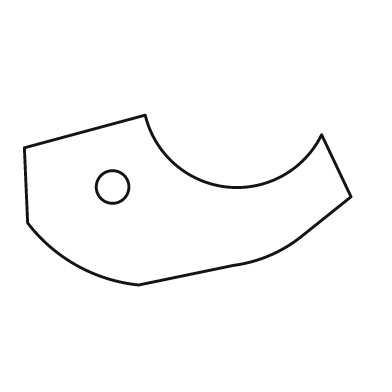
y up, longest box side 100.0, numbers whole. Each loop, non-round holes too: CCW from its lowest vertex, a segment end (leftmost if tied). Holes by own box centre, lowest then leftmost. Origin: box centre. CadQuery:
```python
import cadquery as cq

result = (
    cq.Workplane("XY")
    .moveTo(-15.0, -26.0)
    .lineTo(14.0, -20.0)
    .threePointArc((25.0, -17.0), (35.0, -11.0))
    .lineTo(50.0, 1.0)
    .lineTo(41.0, 20.0)
    .threePointArc((12.0, 4.0), (-13.0, 26.0))
    .lineTo(-50.0, 16.0)
    .lineTo(-49.0, -7.0)
    .threePointArc((-34.0, -20.0), (-15.0, -26.0))
    .close()
    .moveTo(-23.0, 4.0)
    .circle(5.0)
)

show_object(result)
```